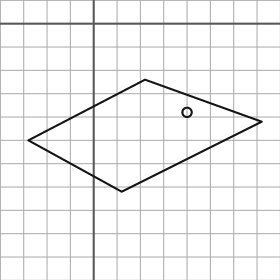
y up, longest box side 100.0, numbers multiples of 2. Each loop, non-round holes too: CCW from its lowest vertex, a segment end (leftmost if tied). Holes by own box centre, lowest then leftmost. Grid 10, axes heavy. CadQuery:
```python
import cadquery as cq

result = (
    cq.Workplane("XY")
    .moveTo(12.0, -72.0)
    .lineTo(72.0, -42.0)
    .lineTo(22.0, -24.0)
    .lineTo(-28.0, -50.0)
    .close()
    .moveTo(40.0, -38.0)
    .circle(2.0)
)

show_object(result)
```